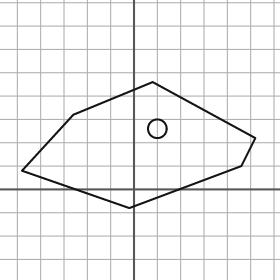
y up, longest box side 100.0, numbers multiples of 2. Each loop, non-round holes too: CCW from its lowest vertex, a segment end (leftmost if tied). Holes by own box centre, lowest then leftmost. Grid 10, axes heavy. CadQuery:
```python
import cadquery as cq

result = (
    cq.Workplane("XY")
    .moveTo(-2.0, -8.0)
    .lineTo(46.0, 10.0)
    .lineTo(52.0, 22.0)
    .lineTo(8.0, 46.0)
    .lineTo(-26.0, 32.0)
    .lineTo(-48.0, 8.0)
    .close()
    .moveTo(10.0, 26.0)
    .circle(4.0)
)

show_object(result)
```